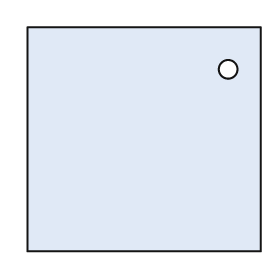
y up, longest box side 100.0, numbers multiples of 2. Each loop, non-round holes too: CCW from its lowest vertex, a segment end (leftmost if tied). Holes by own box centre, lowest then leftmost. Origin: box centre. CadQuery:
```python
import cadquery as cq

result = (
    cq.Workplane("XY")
    .moveTo(-50.0, -48.0)
    .lineTo(50.0, -48.0)
    .lineTo(50.0, 48.0)
    .lineTo(-50.0, 48.0)
    .close()
    .moveTo(36.0, 30.0)
    .circle(4.0)
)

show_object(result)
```